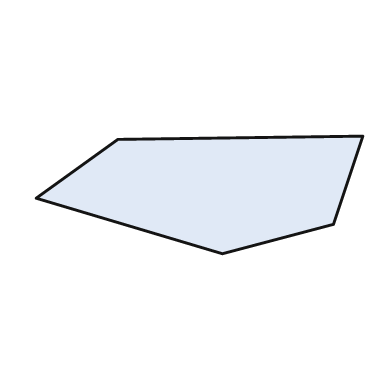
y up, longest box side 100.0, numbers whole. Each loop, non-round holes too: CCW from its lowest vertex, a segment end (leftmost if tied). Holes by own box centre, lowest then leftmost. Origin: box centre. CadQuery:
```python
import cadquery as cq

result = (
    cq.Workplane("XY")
    .moveTo(7.0, -18.0)
    .lineTo(41.0, -9.0)
    .lineTo(50.0, 18.0)
    .lineTo(-25.0, 17.0)
    .lineTo(-50.0, -1.0)
    .close()
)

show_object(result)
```